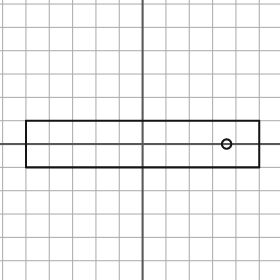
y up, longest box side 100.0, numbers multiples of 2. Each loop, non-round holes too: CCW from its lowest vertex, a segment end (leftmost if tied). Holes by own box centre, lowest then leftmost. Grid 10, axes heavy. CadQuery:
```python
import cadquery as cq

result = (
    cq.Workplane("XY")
    .moveTo(-50.0, -10.0)
    .lineTo(50.0, -10.0)
    .lineTo(50.0, 10.0)
    .lineTo(-50.0, 10.0)
    .close()
    .moveTo(36.0, 0.0)
    .circle(2.0)
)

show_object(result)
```